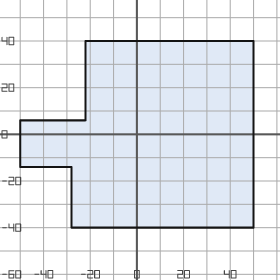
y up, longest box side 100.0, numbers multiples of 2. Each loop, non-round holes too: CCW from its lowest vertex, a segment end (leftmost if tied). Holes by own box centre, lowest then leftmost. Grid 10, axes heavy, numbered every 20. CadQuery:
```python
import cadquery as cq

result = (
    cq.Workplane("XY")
    .moveTo(-28.0, -40.0)
    .lineTo(50.0, -40.0)
    .lineTo(50.0, 40.0)
    .lineTo(-22.0, 40.0)
    .lineTo(-22.0, 6.0)
    .lineTo(-50.0, 6.0)
    .lineTo(-50.0, -14.0)
    .lineTo(-28.0, -14.0)
    .close()
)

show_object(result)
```